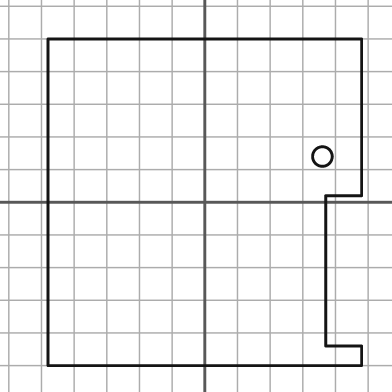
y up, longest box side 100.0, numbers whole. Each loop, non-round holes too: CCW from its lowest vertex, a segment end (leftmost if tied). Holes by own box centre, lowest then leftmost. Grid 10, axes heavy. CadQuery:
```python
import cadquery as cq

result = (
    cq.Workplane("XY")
    .moveTo(-48.0, -50.0)
    .lineTo(48.0, -50.0)
    .lineTo(48.0, -44.0)
    .lineTo(37.0, -44.0)
    .lineTo(37.0, 2.0)
    .lineTo(48.0, 2.0)
    .lineTo(48.0, 50.0)
    .lineTo(-48.0, 50.0)
    .close()
    .moveTo(36.0, 14.0)
    .circle(3.0)
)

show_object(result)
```